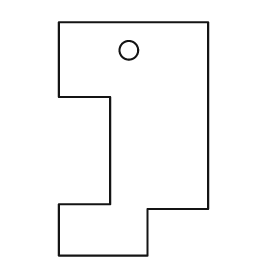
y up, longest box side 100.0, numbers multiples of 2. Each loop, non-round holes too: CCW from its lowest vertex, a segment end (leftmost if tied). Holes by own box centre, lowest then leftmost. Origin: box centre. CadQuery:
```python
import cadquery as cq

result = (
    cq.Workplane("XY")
    .moveTo(-32.0, -50.0)
    .lineTo(6.0, -50.0)
    .lineTo(6.0, -30.0)
    .lineTo(32.0, -30.0)
    .lineTo(32.0, 50.0)
    .lineTo(-32.0, 50.0)
    .lineTo(-32.0, 18.0)
    .lineTo(-10.0, 18.0)
    .lineTo(-10.0, -28.0)
    .lineTo(-32.0, -28.0)
    .close()
    .moveTo(-2.0, 38.0)
    .circle(4.0)
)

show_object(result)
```